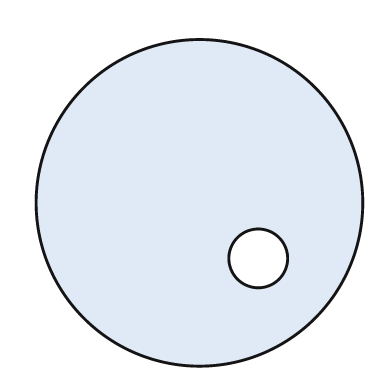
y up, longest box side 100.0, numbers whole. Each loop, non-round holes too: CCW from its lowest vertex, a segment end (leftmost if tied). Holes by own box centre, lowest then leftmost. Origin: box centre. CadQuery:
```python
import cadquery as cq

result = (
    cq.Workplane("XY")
    .moveTo(0.0, 0.0)
    .circle(50.0)
    .moveTo(18.0, -17.0)
    .circle(9.0)
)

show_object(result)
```